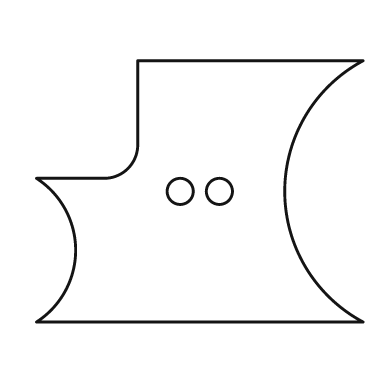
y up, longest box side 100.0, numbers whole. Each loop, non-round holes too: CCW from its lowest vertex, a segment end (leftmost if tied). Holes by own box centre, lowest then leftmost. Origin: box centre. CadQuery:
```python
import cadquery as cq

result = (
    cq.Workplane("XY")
    .moveTo(-50.0, -40.0)
    .lineTo(50.0, -40.0)
    .threePointArc((26.0, 0.0), (50.0, 40.0))
    .lineTo(-19.0, 40.0)
    .lineTo(-19.0, 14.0)
    .threePointArc((-22.0, 7.0), (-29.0, 4.0))
    .lineTo(-50.0, 4.0)
    .threePointArc((-38.0, -18.0), (-50.0, -40.0))
    .close()
    .moveTo(-6.0, 0.0)
    .circle(4.0)
    .moveTo(6.0, 0.0)
    .circle(4.0)
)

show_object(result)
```